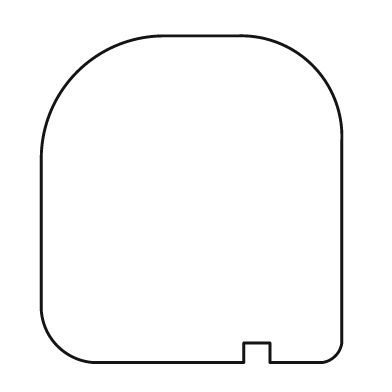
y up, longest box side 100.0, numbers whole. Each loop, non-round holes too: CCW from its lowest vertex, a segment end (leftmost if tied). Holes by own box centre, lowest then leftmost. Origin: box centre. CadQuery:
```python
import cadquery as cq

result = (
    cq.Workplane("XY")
    .moveTo(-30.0, -50.0)
    .lineTo(16.0, -50.0)
    .lineTo(16.0, -44.0)
    .lineTo(24.0, -44.0)
    .lineTo(24.0, -50.0)
    .lineTo(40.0, -50.0)
    .threePointArc((44.0, -48.0), (46.0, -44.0))
    .lineTo(46.0, 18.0)
    .threePointArc((37.0, 41.0), (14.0, 50.0))
    .lineTo(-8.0, 50.0)
    .threePointArc((-35.0, 39.0), (-46.0, 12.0))
    .lineTo(-46.0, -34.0)
    .threePointArc((-41.0, -45.0), (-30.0, -50.0))
    .close()
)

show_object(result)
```